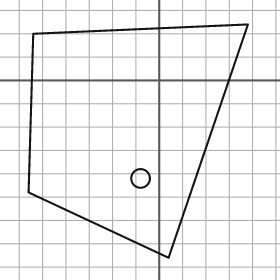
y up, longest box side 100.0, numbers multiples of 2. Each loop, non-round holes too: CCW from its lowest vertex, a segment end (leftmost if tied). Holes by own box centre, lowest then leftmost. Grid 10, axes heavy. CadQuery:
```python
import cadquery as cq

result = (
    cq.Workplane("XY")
    .moveTo(4.0, -76.0)
    .lineTo(38.0, 24.0)
    .lineTo(-54.0, 20.0)
    .lineTo(-56.0, -48.0)
    .close()
    .moveTo(-8.0, -42.0)
    .circle(4.0)
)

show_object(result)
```